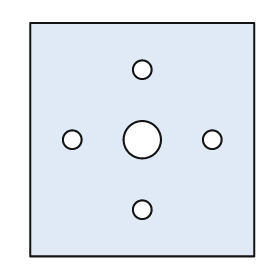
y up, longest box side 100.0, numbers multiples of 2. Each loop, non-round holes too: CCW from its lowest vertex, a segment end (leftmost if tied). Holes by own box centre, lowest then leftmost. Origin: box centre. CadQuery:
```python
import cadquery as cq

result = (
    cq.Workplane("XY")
    .moveTo(-48.0, -50.0)
    .lineTo(48.0, -50.0)
    .lineTo(48.0, 50.0)
    .lineTo(-48.0, 50.0)
    .close()
    .moveTo(0.0, -30.0)
    .circle(4.0)
    .moveTo(-30.0, 0.0)
    .circle(4.0)
    .moveTo(0.0, 0.0)
    .circle(8.0)
    .moveTo(30.0, 0.0)
    .circle(4.0)
    .moveTo(0.0, 30.0)
    .circle(4.0)
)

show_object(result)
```